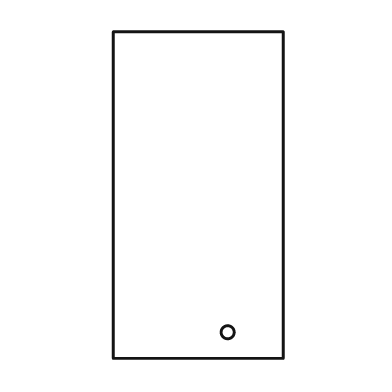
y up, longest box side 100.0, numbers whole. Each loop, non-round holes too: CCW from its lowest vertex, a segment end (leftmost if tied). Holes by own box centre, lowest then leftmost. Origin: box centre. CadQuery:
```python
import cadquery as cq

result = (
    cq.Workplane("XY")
    .moveTo(-26.0, -50.0)
    .lineTo(26.0, -50.0)
    .lineTo(26.0, 50.0)
    .lineTo(-26.0, 50.0)
    .close()
    .moveTo(9.0, -42.0)
    .circle(2.0)
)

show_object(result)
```